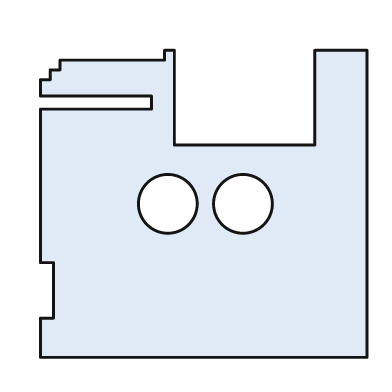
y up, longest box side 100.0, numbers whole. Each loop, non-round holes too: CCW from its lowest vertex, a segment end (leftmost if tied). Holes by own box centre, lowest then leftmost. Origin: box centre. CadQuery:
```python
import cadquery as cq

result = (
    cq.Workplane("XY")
    .moveTo(-50.0, -47.0)
    .lineTo(50.0, -47.0)
    .lineTo(50.0, 47.0)
    .lineTo(34.0, 47.0)
    .lineTo(34.0, 18.0)
    .lineTo(-9.0, 18.0)
    .lineTo(-9.0, 47.0)
    .lineTo(-12.0, 47.0)
    .lineTo(-12.0, 44.0)
    .lineTo(-44.0, 44.0)
    .lineTo(-44.0, 41.0)
    .lineTo(-47.0, 41.0)
    .lineTo(-47.0, 38.0)
    .lineTo(-50.0, 38.0)
    .lineTo(-50.0, 33.0)
    .lineTo(-16.0, 33.0)
    .lineTo(-16.0, 29.0)
    .lineTo(-50.0, 29.0)
    .lineTo(-50.0, -18.0)
    .lineTo(-46.0, -18.0)
    .lineTo(-46.0, -35.0)
    .lineTo(-50.0, -35.0)
    .close()
    .moveTo(-11.0, 0.0)
    .circle(9.0)
    .moveTo(12.0, 0.0)
    .circle(9.0)
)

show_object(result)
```